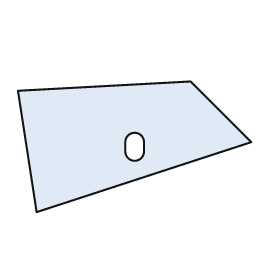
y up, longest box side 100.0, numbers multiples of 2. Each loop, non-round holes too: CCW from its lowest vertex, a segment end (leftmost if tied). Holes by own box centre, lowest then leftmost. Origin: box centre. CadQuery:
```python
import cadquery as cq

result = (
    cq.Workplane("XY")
    .moveTo(-42.0, -28.0)
    .lineTo(50.0, 2.0)
    .lineTo(24.0, 28.0)
    .lineTo(-50.0, 24.0)
    .close()
    .moveTo(-4.0, -2.0)
    .threePointArc((0.0, -6.0), (4.0, -2.0))
    .lineTo(4.0, 2.0)
    .threePointArc((0.0, 6.0), (-4.0, 2.0))
    .close()
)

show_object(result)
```